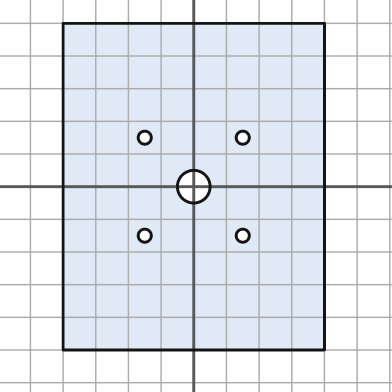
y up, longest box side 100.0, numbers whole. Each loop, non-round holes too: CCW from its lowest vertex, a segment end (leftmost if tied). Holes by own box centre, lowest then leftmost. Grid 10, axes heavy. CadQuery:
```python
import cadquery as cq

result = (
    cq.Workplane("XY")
    .moveTo(-40.0, -50.0)
    .lineTo(40.0, -50.0)
    .lineTo(40.0, 50.0)
    .lineTo(-40.0, 50.0)
    .close()
    .moveTo(-15.0, -15.0)
    .circle(2.0)
    .moveTo(15.0, -15.0)
    .circle(2.0)
    .moveTo(0.0, 0.0)
    .circle(5.0)
    .moveTo(-15.0, 15.0)
    .circle(2.0)
    .moveTo(15.0, 15.0)
    .circle(2.0)
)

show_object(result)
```